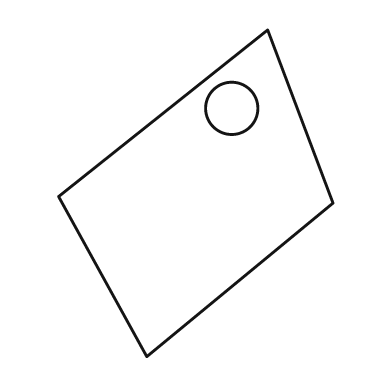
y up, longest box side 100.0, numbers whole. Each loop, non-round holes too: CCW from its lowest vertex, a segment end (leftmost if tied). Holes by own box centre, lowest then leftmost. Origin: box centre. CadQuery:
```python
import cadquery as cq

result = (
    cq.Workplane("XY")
    .moveTo(-15.0, -50.0)
    .lineTo(42.0, -3.0)
    .lineTo(22.0, 50.0)
    .lineTo(-42.0, -1.0)
    .close()
    .moveTo(11.0, 26.0)
    .circle(8.0)
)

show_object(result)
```